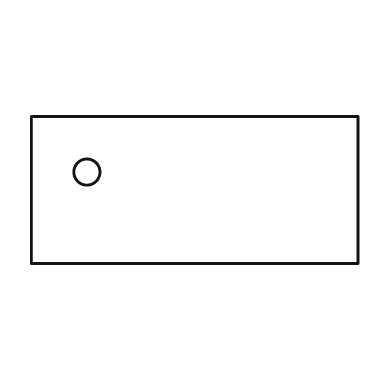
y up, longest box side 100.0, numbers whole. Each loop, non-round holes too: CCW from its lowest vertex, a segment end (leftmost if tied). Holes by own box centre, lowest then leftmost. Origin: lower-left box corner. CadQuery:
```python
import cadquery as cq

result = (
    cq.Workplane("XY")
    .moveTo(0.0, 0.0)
    .lineTo(100.0, 0.0)
    .lineTo(100.0, 45.0)
    .lineTo(0.0, 45.0)
    .close()
    .moveTo(17.0, 28.0)
    .circle(4.0)
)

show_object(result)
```